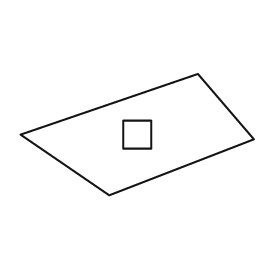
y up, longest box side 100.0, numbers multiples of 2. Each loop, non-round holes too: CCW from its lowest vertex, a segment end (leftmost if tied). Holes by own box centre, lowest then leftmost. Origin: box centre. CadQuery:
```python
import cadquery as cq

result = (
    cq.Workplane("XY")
    .moveTo(-12.0, -26.0)
    .lineTo(50.0, -2.0)
    .lineTo(26.0, 26.0)
    .lineTo(-50.0, 0.0)
    .close()
    .moveTo(-6.0, -6.0)
    .lineTo(6.0, -6.0)
    .lineTo(6.0, 6.0)
    .lineTo(-6.0, 6.0)
    .close()
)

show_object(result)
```